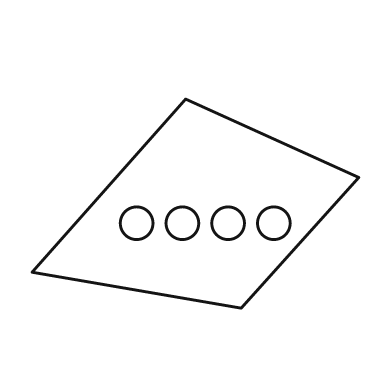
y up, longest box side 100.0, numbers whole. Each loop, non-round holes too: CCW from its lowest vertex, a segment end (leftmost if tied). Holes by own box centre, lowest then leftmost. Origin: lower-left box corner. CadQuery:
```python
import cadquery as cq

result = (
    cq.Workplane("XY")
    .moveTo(64.0, 0.0)
    .lineTo(100.0, 40.0)
    .lineTo(47.0, 64.0)
    .lineTo(0.0, 11.0)
    .close()
    .moveTo(32.0, 26.0)
    .circle(5.0)
    .moveTo(46.0, 26.0)
    .circle(5.0)
    .moveTo(60.0, 26.0)
    .circle(5.0)
    .moveTo(74.0, 26.0)
    .circle(5.0)
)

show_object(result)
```